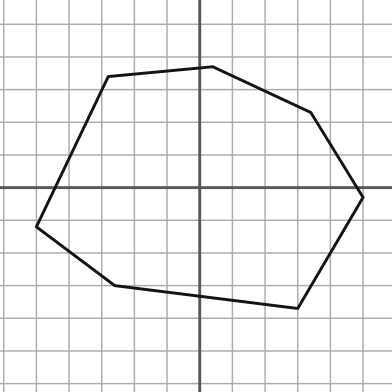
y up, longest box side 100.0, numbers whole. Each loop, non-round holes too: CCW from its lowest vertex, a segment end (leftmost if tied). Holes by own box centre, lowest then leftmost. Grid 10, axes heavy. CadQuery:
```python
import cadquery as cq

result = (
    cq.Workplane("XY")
    .moveTo(30.0, -37.0)
    .lineTo(50.0, -3.0)
    .lineTo(34.0, 23.0)
    .lineTo(4.0, 37.0)
    .lineTo(-28.0, 34.0)
    .lineTo(-50.0, -12.0)
    .lineTo(-26.0, -30.0)
    .close()
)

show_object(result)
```